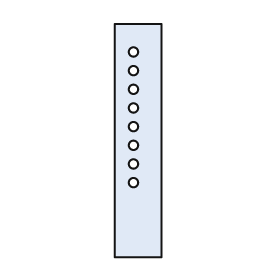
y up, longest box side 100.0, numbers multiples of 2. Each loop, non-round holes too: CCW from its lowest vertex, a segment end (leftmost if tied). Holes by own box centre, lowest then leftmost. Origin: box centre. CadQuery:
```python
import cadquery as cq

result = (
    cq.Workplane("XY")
    .moveTo(-10.0, -50.0)
    .lineTo(10.0, -50.0)
    .lineTo(10.0, 50.0)
    .lineTo(-10.0, 50.0)
    .close()
    .moveTo(-2.0, -18.0)
    .circle(2.0)
    .moveTo(-2.0, -10.0)
    .circle(2.0)
    .moveTo(-2.0, -2.0)
    .circle(2.0)
    .moveTo(-2.0, 6.0)
    .circle(2.0)
    .moveTo(-2.0, 14.0)
    .circle(2.0)
    .moveTo(-2.0, 22.0)
    .circle(2.0)
    .moveTo(-2.0, 30.0)
    .circle(2.0)
    .moveTo(-2.0, 38.0)
    .circle(2.0)
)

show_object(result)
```